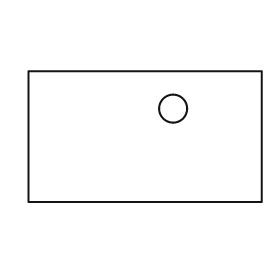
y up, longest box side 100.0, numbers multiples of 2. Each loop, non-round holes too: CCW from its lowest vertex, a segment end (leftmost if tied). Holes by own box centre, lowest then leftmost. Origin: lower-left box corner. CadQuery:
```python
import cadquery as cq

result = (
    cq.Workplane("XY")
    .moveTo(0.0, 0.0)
    .lineTo(100.0, 0.0)
    .lineTo(100.0, 56.0)
    .lineTo(0.0, 56.0)
    .close()
    .moveTo(62.0, 40.0)
    .circle(6.0)
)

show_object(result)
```